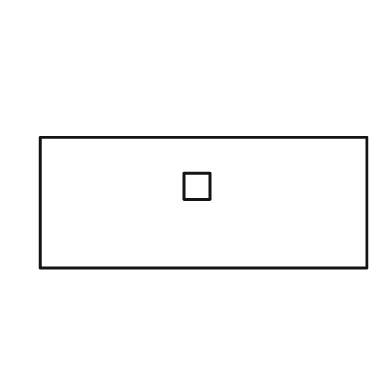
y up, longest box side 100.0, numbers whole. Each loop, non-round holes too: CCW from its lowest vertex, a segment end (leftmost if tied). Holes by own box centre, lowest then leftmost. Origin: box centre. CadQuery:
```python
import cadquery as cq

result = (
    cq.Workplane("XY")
    .moveTo(-50.0, -20.0)
    .lineTo(50.0, -20.0)
    .lineTo(50.0, 20.0)
    .lineTo(-50.0, 20.0)
    .close()
    .moveTo(-6.0, 1.0)
    .lineTo(2.0, 1.0)
    .lineTo(2.0, 9.0)
    .lineTo(-6.0, 9.0)
    .close()
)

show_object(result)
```